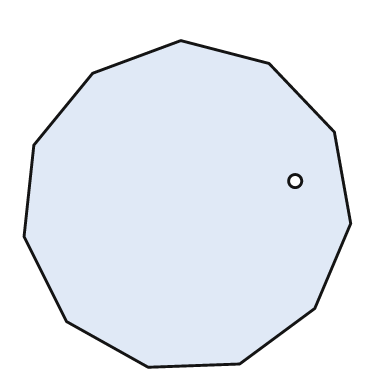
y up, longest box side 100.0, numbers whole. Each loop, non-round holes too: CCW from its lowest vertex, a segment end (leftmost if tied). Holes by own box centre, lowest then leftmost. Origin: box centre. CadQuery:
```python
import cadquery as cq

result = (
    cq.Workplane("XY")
    .moveTo(-12.0, -50.0)
    .lineTo(16.0, -49.0)
    .lineTo(39.0, -32.0)
    .lineTo(50.0, -6.0)
    .lineTo(45.0, 22.0)
    .lineTo(25.0, 43.0)
    .lineTo(-2.0, 50.0)
    .lineTo(-29.0, 40.0)
    .lineTo(-47.0, 18.0)
    .lineTo(-50.0, -10.0)
    .lineTo(-37.0, -36.0)
    .close()
    .moveTo(33.0, 7.0)
    .circle(2.0)
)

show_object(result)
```